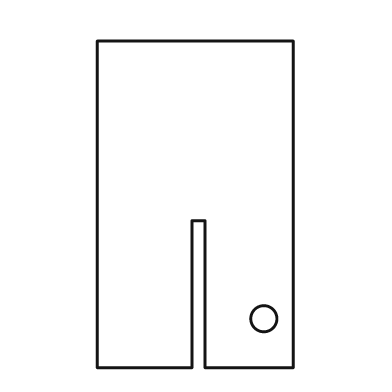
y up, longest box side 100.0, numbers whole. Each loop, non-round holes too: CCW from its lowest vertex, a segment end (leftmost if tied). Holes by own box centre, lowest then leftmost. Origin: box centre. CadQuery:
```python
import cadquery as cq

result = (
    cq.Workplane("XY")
    .moveTo(-30.0, -50.0)
    .lineTo(-1.0, -50.0)
    .lineTo(-1.0, -5.0)
    .lineTo(3.0, -5.0)
    .lineTo(3.0, -50.0)
    .lineTo(30.0, -50.0)
    .lineTo(30.0, 50.0)
    .lineTo(-30.0, 50.0)
    .close()
    .moveTo(21.0, -35.0)
    .circle(4.0)
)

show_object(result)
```